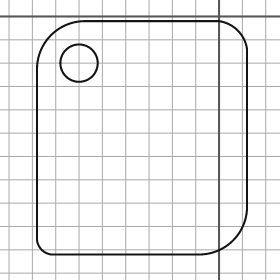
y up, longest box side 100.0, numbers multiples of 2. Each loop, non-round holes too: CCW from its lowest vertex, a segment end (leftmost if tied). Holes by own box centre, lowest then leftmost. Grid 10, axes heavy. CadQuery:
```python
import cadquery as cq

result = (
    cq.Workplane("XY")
    .moveTo(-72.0, -102.0)
    .lineTo(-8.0, -102.0)
    .threePointArc((6.0, -96.0), (12.0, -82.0))
    .lineTo(12.0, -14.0)
    .threePointArc((8.0, -6.0), (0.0, -2.0))
    .lineTo(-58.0, -2.0)
    .threePointArc((-72.0, -8.0), (-78.0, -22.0))
    .lineTo(-78.0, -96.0)
    .threePointArc((-76.0, -100.0), (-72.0, -102.0))
    .close()
    .moveTo(-60.0, -20.0)
    .circle(8.0)
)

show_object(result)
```